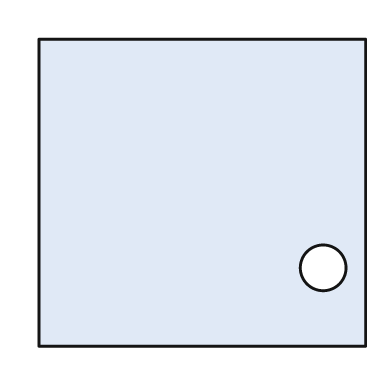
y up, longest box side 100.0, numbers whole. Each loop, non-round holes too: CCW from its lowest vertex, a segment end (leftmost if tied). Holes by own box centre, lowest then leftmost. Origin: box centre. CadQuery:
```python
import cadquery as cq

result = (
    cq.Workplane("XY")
    .moveTo(-50.0, -47.0)
    .lineTo(50.0, -47.0)
    .lineTo(50.0, 47.0)
    .lineTo(-50.0, 47.0)
    .close()
    .moveTo(37.0, -23.0)
    .circle(7.0)
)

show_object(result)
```